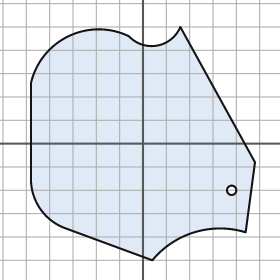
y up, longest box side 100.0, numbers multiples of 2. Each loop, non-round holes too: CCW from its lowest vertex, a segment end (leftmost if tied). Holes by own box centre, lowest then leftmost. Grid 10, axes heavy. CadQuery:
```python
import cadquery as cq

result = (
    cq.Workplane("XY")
    .moveTo(4.0, -50.0)
    .threePointArc((22.0, -38.0), (44.0, -38.0))
    .lineTo(48.0, -8.0)
    .lineTo(16.0, 50.0)
    .threePointArc((6.0, 42.0), (-6.0, 46.0))
    .threePointArc((-32.0, 46.0), (-48.0, 26.0))
    .lineTo(-48.0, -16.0)
    .threePointArc((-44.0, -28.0), (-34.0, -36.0))
    .close()
    .moveTo(38.0, -20.0)
    .circle(2.0)
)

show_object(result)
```